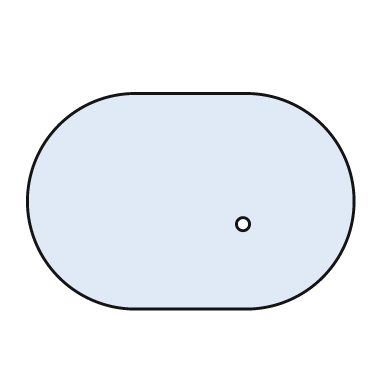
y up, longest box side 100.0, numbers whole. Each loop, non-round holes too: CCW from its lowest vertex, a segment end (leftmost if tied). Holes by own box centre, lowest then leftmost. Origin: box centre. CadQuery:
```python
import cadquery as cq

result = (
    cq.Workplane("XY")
    .moveTo(-17.0, -33.0)
    .lineTo(17.0, -33.0)
    .threePointArc((50.0, 0.0), (17.0, 33.0))
    .lineTo(-17.0, 33.0)
    .threePointArc((-50.0, 0.0), (-17.0, -33.0))
    .close()
    .moveTo(16.0, -7.0)
    .circle(2.0)
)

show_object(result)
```